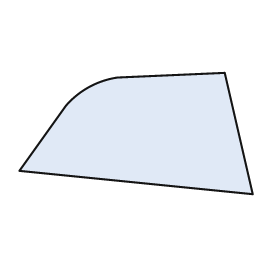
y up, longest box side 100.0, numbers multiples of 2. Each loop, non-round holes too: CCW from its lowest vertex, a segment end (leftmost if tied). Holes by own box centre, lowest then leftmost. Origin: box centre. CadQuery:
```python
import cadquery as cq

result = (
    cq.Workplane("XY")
    .moveTo(50.0, -26.0)
    .lineTo(38.0, 26.0)
    .lineTo(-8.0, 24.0)
    .threePointArc((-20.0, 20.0), (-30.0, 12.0))
    .lineTo(-50.0, -16.0)
    .close()
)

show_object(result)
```